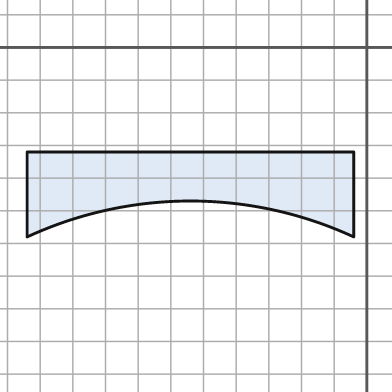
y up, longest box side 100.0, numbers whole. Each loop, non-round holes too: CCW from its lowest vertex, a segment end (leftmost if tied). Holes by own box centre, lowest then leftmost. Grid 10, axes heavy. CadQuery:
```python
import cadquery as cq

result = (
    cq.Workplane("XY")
    .moveTo(-104.0, -58.0)
    .threePointArc((-54.0, -47.0), (-4.0, -58.0))
    .lineTo(-4.0, -32.0)
    .lineTo(-104.0, -32.0)
    .close()
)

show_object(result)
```